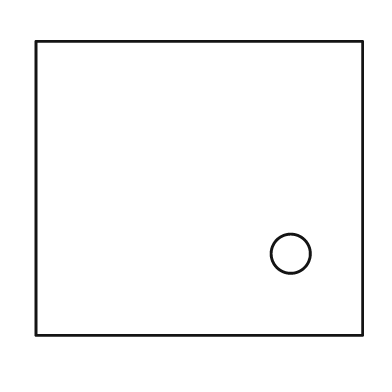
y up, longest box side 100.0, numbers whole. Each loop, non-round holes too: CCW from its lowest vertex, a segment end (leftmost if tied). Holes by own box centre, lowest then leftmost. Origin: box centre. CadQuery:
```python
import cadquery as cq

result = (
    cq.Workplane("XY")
    .moveTo(-50.0, -45.0)
    .lineTo(50.0, -45.0)
    .lineTo(50.0, 45.0)
    .lineTo(-50.0, 45.0)
    .close()
    .moveTo(28.0, -20.0)
    .circle(6.0)
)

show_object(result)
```